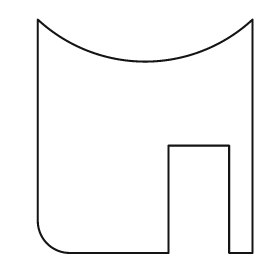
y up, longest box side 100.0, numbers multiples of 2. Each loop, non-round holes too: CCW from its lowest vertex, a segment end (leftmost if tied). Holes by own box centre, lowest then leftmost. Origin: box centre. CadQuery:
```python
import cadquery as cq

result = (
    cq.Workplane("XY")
    .moveTo(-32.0, -50.0)
    .lineTo(10.0, -50.0)
    .lineTo(10.0, -4.0)
    .lineTo(36.0, -4.0)
    .lineTo(36.0, -50.0)
    .lineTo(46.0, -50.0)
    .lineTo(46.0, 50.0)
    .threePointArc((0.0, 32.0), (-46.0, 50.0))
    .lineTo(-46.0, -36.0)
    .threePointArc((-42.0, -46.0), (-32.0, -50.0))
    .close()
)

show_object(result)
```